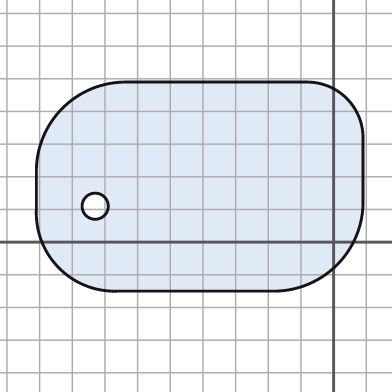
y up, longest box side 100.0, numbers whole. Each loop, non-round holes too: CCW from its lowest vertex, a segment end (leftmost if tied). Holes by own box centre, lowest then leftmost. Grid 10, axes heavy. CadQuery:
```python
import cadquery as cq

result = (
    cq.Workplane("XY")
    .moveTo(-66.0, -15.0)
    .lineTo(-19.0, -15.0)
    .threePointArc((1.0, -7.0), (9.0, 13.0))
    .lineTo(9.0, 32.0)
    .threePointArc((4.0, 44.0), (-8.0, 49.0))
    .lineTo(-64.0, 49.0)
    .threePointArc((-83.0, 41.0), (-91.0, 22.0))
    .lineTo(-91.0, 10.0)
    .threePointArc((-84.0, -8.0), (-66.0, -15.0))
    .close()
    .moveTo(-73.0, 11.0)
    .circle(4.0)
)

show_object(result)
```